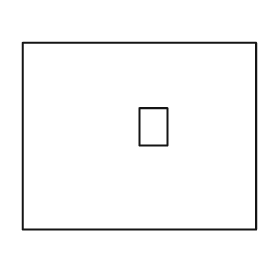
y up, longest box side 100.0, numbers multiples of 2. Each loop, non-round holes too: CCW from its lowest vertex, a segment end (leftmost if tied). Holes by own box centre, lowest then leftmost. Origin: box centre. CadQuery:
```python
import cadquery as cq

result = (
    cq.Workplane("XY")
    .moveTo(-50.0, -40.0)
    .lineTo(50.0, -40.0)
    .lineTo(50.0, 40.0)
    .lineTo(-50.0, 40.0)
    .close()
    .moveTo(0.0, -4.0)
    .lineTo(12.0, -4.0)
    .lineTo(12.0, 12.0)
    .lineTo(0.0, 12.0)
    .close()
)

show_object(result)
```